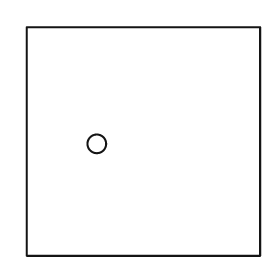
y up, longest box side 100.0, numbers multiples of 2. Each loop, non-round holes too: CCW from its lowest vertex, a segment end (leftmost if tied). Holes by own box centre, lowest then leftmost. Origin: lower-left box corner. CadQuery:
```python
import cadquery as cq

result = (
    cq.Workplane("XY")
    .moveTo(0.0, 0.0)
    .lineTo(100.0, 0.0)
    .lineTo(100.0, 98.0)
    .lineTo(0.0, 98.0)
    .close()
    .moveTo(30.0, 48.0)
    .circle(4.0)
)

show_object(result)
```